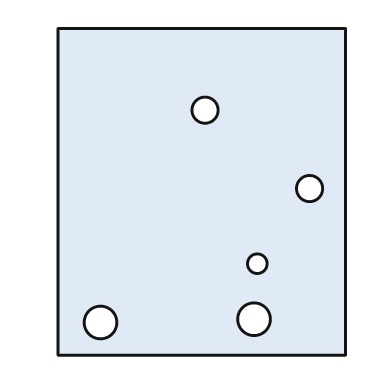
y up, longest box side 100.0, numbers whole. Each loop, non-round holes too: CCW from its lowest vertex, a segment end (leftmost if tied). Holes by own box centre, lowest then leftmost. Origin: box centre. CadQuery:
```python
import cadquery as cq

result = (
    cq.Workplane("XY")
    .moveTo(-44.0, -50.0)
    .lineTo(44.0, -50.0)
    .lineTo(44.0, 50.0)
    .lineTo(-44.0, 50.0)
    .close()
    .moveTo(-31.0, -40.0)
    .circle(5.0)
    .moveTo(16.0, -39.0)
    .circle(5.0)
    .moveTo(17.0, -22.0)
    .circle(3.0)
    .moveTo(33.0, 1.0)
    .circle(4.0)
    .moveTo(1.0, 25.0)
    .circle(4.0)
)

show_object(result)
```